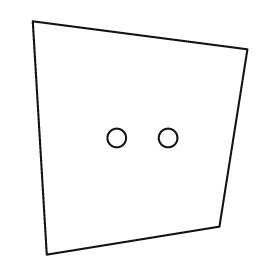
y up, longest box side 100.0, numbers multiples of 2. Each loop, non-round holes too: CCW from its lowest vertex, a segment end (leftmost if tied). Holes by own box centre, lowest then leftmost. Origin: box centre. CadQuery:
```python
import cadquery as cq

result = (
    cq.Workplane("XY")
    .moveTo(-40.0, -50.0)
    .lineTo(34.0, -38.0)
    .lineTo(46.0, 38.0)
    .lineTo(-46.0, 50.0)
    .close()
    .moveTo(-10.0, 0.0)
    .circle(4.0)
    .moveTo(12.0, 0.0)
    .circle(4.0)
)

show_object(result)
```